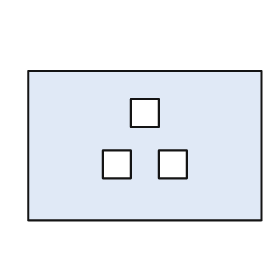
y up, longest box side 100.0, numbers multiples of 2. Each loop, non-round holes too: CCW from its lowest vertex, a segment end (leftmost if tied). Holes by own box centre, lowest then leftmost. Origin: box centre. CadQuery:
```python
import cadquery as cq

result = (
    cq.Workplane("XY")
    .moveTo(-50.0, -32.0)
    .lineTo(50.0, -32.0)
    .lineTo(50.0, 32.0)
    .lineTo(-50.0, 32.0)
    .close()
    .moveTo(-18.0, -14.0)
    .lineTo(-6.0, -14.0)
    .lineTo(-6.0, -2.0)
    .lineTo(-18.0, -2.0)
    .close()
    .moveTo(6.0, -14.0)
    .lineTo(18.0, -14.0)
    .lineTo(18.0, -2.0)
    .lineTo(6.0, -2.0)
    .close()
    .moveTo(-6.0, 8.0)
    .lineTo(6.0, 8.0)
    .lineTo(6.0, 20.0)
    .lineTo(-6.0, 20.0)
    .close()
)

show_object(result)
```